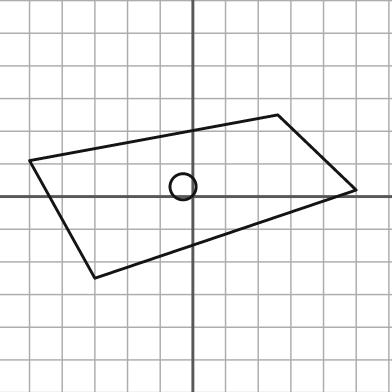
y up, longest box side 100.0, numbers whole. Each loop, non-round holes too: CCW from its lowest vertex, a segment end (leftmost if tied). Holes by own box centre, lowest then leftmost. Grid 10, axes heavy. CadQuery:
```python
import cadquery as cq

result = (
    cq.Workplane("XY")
    .moveTo(-30.0, -25.0)
    .lineTo(50.0, 2.0)
    .lineTo(26.0, 25.0)
    .lineTo(-50.0, 11.0)
    .close()
    .moveTo(-3.0, 3.0)
    .circle(4.0)
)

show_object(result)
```